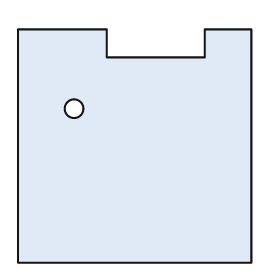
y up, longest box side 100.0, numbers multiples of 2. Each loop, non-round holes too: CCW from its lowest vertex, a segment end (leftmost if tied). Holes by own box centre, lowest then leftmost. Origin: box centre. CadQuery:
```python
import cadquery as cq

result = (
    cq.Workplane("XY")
    .moveTo(-50.0, -50.0)
    .lineTo(50.0, -50.0)
    .lineTo(50.0, 50.0)
    .lineTo(30.0, 50.0)
    .lineTo(30.0, 38.0)
    .lineTo(-12.0, 38.0)
    .lineTo(-12.0, 50.0)
    .lineTo(-50.0, 50.0)
    .close()
    .moveTo(-26.0, 16.0)
    .circle(4.0)
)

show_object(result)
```